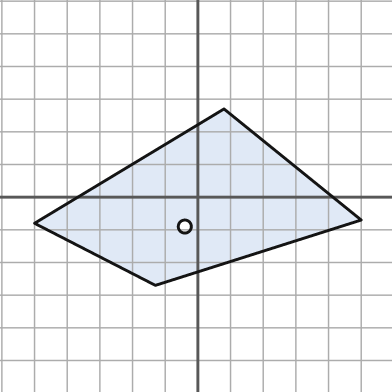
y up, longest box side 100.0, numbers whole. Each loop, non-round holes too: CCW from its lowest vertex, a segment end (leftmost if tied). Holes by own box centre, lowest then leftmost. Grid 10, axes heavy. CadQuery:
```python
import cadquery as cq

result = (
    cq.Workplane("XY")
    .moveTo(-13.0, -27.0)
    .lineTo(50.0, -7.0)
    .lineTo(8.0, 27.0)
    .lineTo(-50.0, -8.0)
    .close()
    .moveTo(-4.0, -9.0)
    .circle(2.0)
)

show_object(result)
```